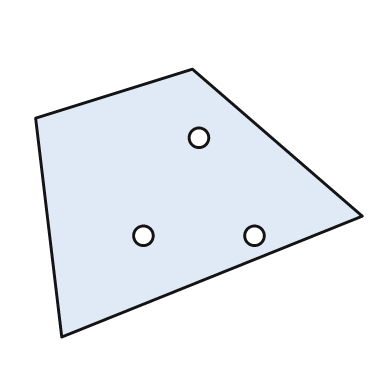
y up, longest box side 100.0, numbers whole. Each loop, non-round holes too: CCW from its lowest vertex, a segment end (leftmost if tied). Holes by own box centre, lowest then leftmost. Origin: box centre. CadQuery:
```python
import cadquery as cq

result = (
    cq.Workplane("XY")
    .moveTo(-42.0, -41.0)
    .lineTo(50.0, -4.0)
    .lineTo(-2.0, 41.0)
    .lineTo(-50.0, 26.0)
    .close()
    .moveTo(-17.0, -10.0)
    .circle(3.0)
    .moveTo(17.0, -10.0)
    .circle(3.0)
    .moveTo(0.0, 20.0)
    .circle(3.0)
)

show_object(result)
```